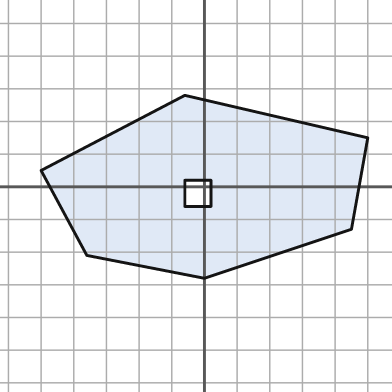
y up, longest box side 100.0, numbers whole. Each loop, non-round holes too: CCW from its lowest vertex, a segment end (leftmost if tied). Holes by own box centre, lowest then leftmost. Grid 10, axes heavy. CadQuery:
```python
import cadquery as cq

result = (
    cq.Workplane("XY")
    .moveTo(0.0, -28.0)
    .lineTo(45.0, -13.0)
    .lineTo(50.0, 15.0)
    .lineTo(-6.0, 28.0)
    .lineTo(-50.0, 5.0)
    .lineTo(-36.0, -21.0)
    .close()
    .moveTo(-6.0, -6.0)
    .lineTo(2.0, -6.0)
    .lineTo(2.0, 2.0)
    .lineTo(-6.0, 2.0)
    .close()
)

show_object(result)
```